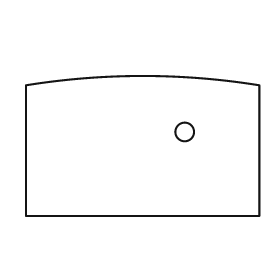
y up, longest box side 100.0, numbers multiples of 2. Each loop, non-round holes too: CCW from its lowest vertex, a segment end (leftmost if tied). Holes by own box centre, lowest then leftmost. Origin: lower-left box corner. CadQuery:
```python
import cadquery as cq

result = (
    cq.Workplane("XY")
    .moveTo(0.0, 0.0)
    .lineTo(100.0, 0.0)
    .lineTo(100.0, 56.0)
    .threePointArc((50.0, 60.0), (0.0, 56.0))
    .close()
    .moveTo(68.0, 36.0)
    .circle(4.0)
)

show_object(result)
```